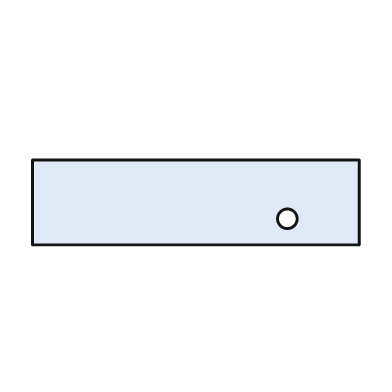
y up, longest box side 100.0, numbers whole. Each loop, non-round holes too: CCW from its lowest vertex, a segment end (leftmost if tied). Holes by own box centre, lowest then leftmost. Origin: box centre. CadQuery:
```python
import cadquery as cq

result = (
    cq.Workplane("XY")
    .moveTo(-50.0, -13.0)
    .lineTo(50.0, -13.0)
    .lineTo(50.0, 13.0)
    .lineTo(-50.0, 13.0)
    .close()
    .moveTo(28.0, -5.0)
    .circle(3.0)
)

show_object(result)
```